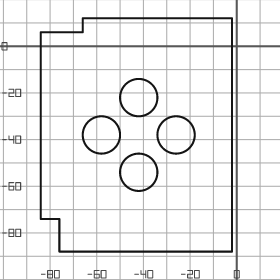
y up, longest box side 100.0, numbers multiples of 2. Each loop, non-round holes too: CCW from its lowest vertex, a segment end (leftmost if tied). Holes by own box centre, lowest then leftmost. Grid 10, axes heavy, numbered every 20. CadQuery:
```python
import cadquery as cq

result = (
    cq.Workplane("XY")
    .moveTo(-76.0, -88.0)
    .lineTo(-2.0, -88.0)
    .lineTo(-2.0, 12.0)
    .lineTo(-66.0, 12.0)
    .lineTo(-66.0, 6.0)
    .lineTo(-84.0, 6.0)
    .lineTo(-84.0, -74.0)
    .lineTo(-76.0, -74.0)
    .close()
    .moveTo(-42.0, -54.0)
    .circle(8.0)
    .moveTo(-58.0, -38.0)
    .circle(8.0)
    .moveTo(-26.0, -38.0)
    .circle(8.0)
    .moveTo(-42.0, -22.0)
    .circle(8.0)
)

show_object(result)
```